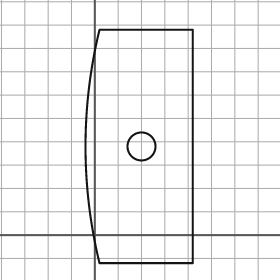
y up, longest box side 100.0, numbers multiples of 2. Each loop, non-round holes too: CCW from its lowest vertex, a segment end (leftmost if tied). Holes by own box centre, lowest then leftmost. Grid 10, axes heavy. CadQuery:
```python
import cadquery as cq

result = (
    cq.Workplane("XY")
    .moveTo(2.0, -12.0)
    .lineTo(42.0, -12.0)
    .lineTo(42.0, 88.0)
    .lineTo(2.0, 88.0)
    .threePointArc((-4.0, 38.0), (2.0, -12.0))
    .close()
    .moveTo(20.0, 38.0)
    .circle(6.0)
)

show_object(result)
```